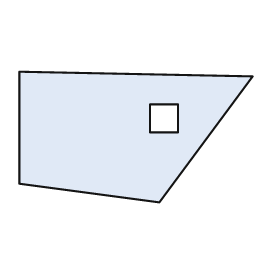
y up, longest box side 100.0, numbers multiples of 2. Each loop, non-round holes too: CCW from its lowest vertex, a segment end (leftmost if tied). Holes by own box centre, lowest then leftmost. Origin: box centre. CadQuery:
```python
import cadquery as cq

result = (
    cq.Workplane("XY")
    .moveTo(10.0, -28.0)
    .lineTo(50.0, 26.0)
    .lineTo(-50.0, 28.0)
    .lineTo(-50.0, -20.0)
    .close()
    .moveTo(6.0, 2.0)
    .lineTo(18.0, 2.0)
    .lineTo(18.0, 14.0)
    .lineTo(6.0, 14.0)
    .close()
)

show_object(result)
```